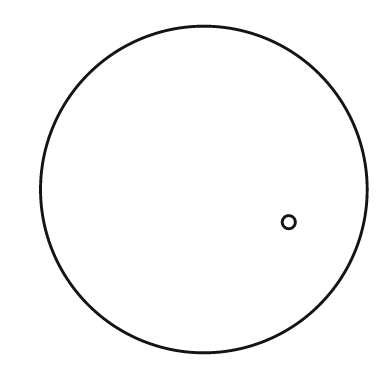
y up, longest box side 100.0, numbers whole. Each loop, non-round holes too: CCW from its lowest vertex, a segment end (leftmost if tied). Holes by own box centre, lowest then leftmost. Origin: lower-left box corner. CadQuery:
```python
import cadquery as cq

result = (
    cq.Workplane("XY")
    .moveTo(50.0, 50.0)
    .circle(50.0)
    .moveTo(76.0, 40.0)
    .circle(2.0)
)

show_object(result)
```